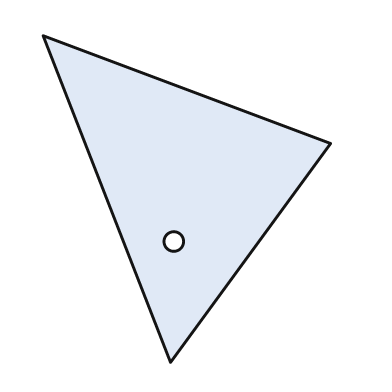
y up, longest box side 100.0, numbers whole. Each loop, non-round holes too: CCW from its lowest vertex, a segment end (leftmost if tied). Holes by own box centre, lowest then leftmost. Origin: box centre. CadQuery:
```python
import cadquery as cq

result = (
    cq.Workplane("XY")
    .moveTo(-5.0, -50.0)
    .lineTo(44.0, 17.0)
    .lineTo(-44.0, 50.0)
    .close()
    .moveTo(-4.0, -13.0)
    .circle(3.0)
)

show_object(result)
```